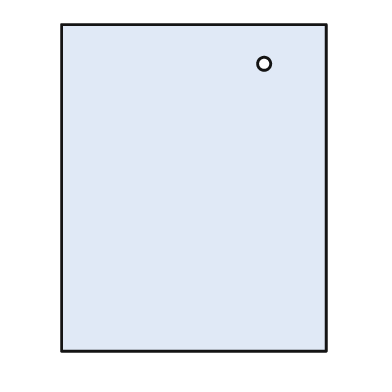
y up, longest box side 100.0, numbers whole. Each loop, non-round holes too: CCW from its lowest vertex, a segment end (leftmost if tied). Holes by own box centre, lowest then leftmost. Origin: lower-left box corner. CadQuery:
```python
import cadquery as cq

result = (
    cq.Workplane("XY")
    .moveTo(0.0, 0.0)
    .lineTo(81.0, 0.0)
    .lineTo(81.0, 100.0)
    .lineTo(0.0, 100.0)
    .close()
    .moveTo(62.0, 88.0)
    .circle(2.0)
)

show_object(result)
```